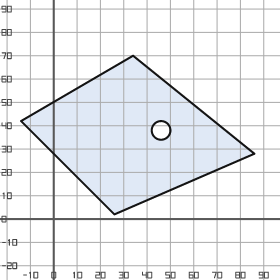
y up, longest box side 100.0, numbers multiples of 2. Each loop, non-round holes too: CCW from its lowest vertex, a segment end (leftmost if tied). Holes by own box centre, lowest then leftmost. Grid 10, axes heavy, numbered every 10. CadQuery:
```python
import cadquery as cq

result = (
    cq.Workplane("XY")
    .moveTo(26.0, 2.0)
    .lineTo(86.0, 28.0)
    .lineTo(34.0, 70.0)
    .lineTo(-14.0, 42.0)
    .close()
    .moveTo(46.0, 38.0)
    .circle(4.0)
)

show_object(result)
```